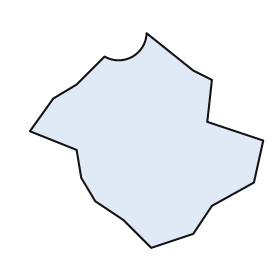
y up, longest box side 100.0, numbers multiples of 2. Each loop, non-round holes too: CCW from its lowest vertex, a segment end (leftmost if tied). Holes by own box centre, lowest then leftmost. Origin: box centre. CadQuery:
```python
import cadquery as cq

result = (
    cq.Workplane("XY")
    .moveTo(2.0, -46.0)
    .lineTo(20.0, -40.0)
    .lineTo(28.0, -28.0)
    .lineTo(46.0, -18.0)
    .lineTo(50.0, 0.0)
    .lineTo(26.0, 8.0)
    .lineTo(28.0, 26.0)
    .lineTo(20.0, 30.0)
    .lineTo(0.0, 46.0)
    .threePointArc((-6.0, 36.0), (-18.0, 36.0))
    .lineTo(-30.0, 24.0)
    .lineTo(-40.0, 18.0)
    .lineTo(-50.0, 4.0)
    .lineTo(-30.0, -4.0)
    .lineTo(-28.0, -16.0)
    .lineTo(-22.0, -26.0)
    .lineTo(-10.0, -34.0)
    .close()
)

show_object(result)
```